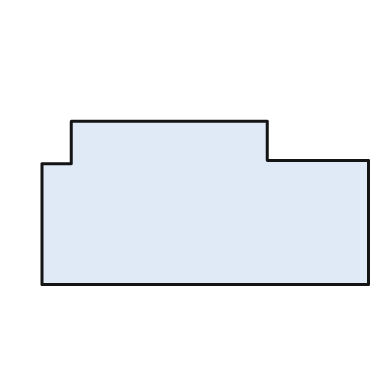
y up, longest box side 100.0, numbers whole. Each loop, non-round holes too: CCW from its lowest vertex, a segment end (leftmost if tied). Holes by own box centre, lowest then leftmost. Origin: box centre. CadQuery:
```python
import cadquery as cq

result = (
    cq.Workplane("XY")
    .moveTo(-50.0, -25.0)
    .lineTo(50.0, -25.0)
    .lineTo(50.0, 13.0)
    .lineTo(19.0, 13.0)
    .lineTo(19.0, 25.0)
    .lineTo(-41.0, 25.0)
    .lineTo(-41.0, 12.0)
    .lineTo(-50.0, 12.0)
    .close()
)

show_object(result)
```